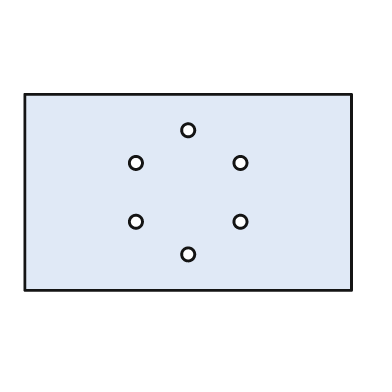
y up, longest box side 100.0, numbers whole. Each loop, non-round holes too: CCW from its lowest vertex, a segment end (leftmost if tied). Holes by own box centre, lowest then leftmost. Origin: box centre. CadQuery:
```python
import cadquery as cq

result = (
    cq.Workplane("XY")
    .moveTo(-50.0, -30.0)
    .lineTo(50.0, -30.0)
    .lineTo(50.0, 30.0)
    .lineTo(-50.0, 30.0)
    .close()
    .moveTo(0.0, -19.0)
    .circle(2.0)
    .moveTo(-16.0, -9.0)
    .circle(2.0)
    .moveTo(16.0, -9.0)
    .circle(2.0)
    .moveTo(-16.0, 9.0)
    .circle(2.0)
    .moveTo(16.0, 9.0)
    .circle(2.0)
    .moveTo(0.0, 19.0)
    .circle(2.0)
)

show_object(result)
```